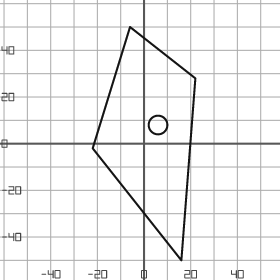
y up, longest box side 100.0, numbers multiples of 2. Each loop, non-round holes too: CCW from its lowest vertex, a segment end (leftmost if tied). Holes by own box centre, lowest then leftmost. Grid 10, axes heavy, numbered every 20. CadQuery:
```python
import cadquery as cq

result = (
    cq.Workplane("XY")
    .moveTo(16.0, -50.0)
    .lineTo(22.0, 28.0)
    .lineTo(-6.0, 50.0)
    .lineTo(-22.0, -2.0)
    .close()
    .moveTo(6.0, 8.0)
    .circle(4.0)
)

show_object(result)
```